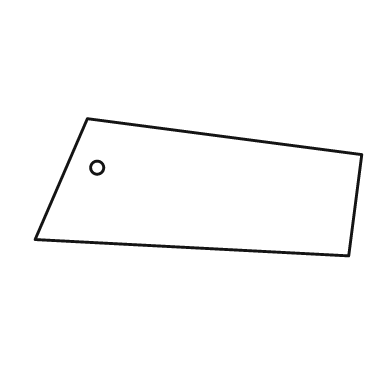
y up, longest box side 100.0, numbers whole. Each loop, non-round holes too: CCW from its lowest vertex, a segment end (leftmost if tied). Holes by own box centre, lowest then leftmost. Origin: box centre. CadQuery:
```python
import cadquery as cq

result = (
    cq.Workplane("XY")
    .moveTo(46.0, -21.0)
    .lineTo(50.0, 10.0)
    .lineTo(-34.0, 21.0)
    .lineTo(-50.0, -16.0)
    .close()
    .moveTo(-31.0, 6.0)
    .circle(2.0)
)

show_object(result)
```